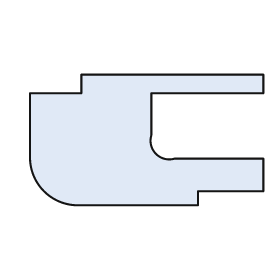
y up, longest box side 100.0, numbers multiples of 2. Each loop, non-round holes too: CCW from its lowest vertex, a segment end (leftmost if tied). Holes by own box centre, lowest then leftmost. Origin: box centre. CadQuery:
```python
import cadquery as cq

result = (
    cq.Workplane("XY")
    .moveTo(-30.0, -28.0)
    .lineTo(22.0, -28.0)
    .lineTo(22.0, -22.0)
    .lineTo(50.0, -22.0)
    .lineTo(50.0, -8.0)
    .lineTo(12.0, -8.0)
    .threePointArc((4.0, -6.0), (2.0, 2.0))
    .lineTo(2.0, 20.0)
    .lineTo(50.0, 20.0)
    .lineTo(50.0, 28.0)
    .lineTo(-28.0, 28.0)
    .lineTo(-28.0, 20.0)
    .lineTo(-50.0, 20.0)
    .lineTo(-50.0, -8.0)
    .threePointArc((-44.0, -22.0), (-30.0, -28.0))
    .close()
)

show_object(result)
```